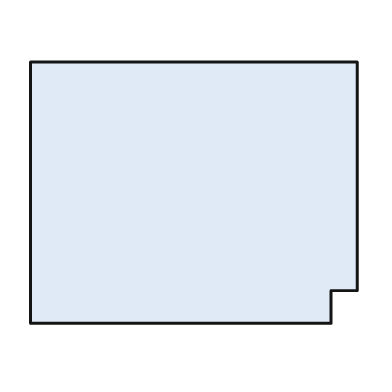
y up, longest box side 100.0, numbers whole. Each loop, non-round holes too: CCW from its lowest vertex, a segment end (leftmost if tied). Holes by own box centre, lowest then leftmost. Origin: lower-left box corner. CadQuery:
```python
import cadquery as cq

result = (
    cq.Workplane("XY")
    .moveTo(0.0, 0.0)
    .lineTo(92.0, 0.0)
    .lineTo(92.0, 10.0)
    .lineTo(100.0, 10.0)
    .lineTo(100.0, 80.0)
    .lineTo(0.0, 80.0)
    .close()
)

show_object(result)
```